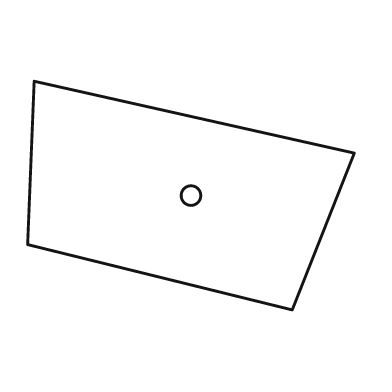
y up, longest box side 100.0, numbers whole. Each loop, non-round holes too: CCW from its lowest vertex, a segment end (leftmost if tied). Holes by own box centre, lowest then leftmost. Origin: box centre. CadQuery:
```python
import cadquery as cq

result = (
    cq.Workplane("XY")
    .moveTo(31.0, -35.0)
    .lineTo(50.0, 13.0)
    .lineTo(-48.0, 35.0)
    .lineTo(-50.0, -15.0)
    .close()
    .moveTo(0.0, 0.0)
    .circle(3.0)
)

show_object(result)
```